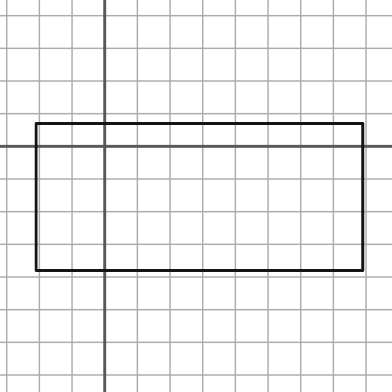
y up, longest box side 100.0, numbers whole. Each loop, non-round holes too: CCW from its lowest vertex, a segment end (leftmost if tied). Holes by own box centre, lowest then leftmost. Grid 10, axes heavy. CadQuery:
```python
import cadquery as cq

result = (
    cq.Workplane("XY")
    .moveTo(-21.0, -38.0)
    .lineTo(79.0, -38.0)
    .lineTo(79.0, 7.0)
    .lineTo(-21.0, 7.0)
    .close()
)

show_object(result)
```